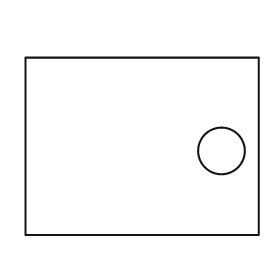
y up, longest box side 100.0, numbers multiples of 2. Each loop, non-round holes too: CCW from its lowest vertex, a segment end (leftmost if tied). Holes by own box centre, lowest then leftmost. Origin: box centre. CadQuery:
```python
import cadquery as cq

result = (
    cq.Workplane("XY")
    .moveTo(-50.0, -38.0)
    .lineTo(50.0, -38.0)
    .lineTo(50.0, 38.0)
    .lineTo(-50.0, 38.0)
    .close()
    .moveTo(34.0, -2.0)
    .circle(10.0)
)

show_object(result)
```